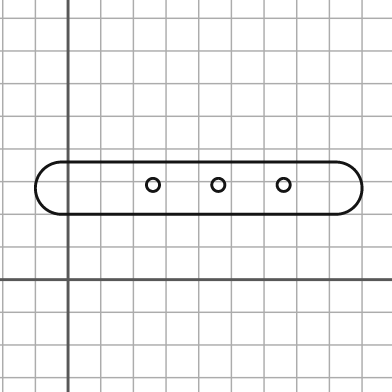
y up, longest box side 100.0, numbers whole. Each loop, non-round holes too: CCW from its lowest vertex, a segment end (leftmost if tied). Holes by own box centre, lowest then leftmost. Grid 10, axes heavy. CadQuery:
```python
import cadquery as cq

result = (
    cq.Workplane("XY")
    .moveTo(-2.0, 20.0)
    .lineTo(82.0, 20.0)
    .threePointArc((90.0, 28.0), (82.0, 36.0))
    .lineTo(-2.0, 36.0)
    .threePointArc((-10.0, 28.0), (-2.0, 20.0))
    .close()
    .moveTo(26.0, 29.0)
    .circle(2.0)
    .moveTo(46.0, 29.0)
    .circle(2.0)
    .moveTo(66.0, 29.0)
    .circle(2.0)
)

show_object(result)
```